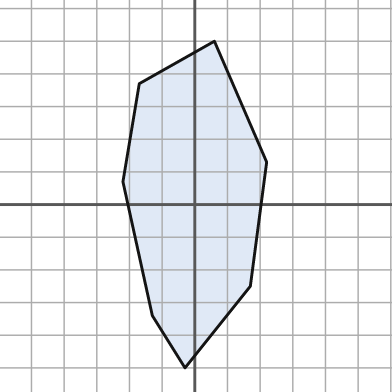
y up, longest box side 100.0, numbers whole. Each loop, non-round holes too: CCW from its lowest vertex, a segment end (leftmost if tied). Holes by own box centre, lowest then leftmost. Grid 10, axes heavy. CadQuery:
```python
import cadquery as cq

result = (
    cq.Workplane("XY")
    .moveTo(-3.0, -50.0)
    .lineTo(17.0, -25.0)
    .lineTo(22.0, 13.0)
    .lineTo(6.0, 50.0)
    .lineTo(-17.0, 37.0)
    .lineTo(-22.0, 7.0)
    .lineTo(-13.0, -34.0)
    .close()
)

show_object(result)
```